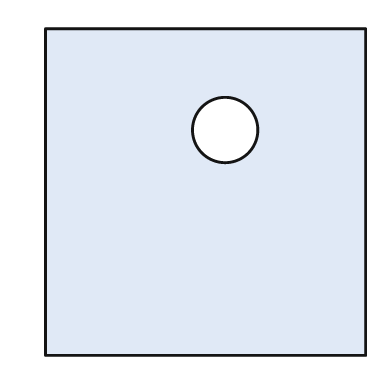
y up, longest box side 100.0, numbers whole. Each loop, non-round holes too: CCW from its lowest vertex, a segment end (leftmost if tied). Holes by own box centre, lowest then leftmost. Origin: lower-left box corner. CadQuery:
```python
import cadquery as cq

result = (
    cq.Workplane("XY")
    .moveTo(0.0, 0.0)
    .lineTo(98.0, 0.0)
    .lineTo(98.0, 100.0)
    .lineTo(0.0, 100.0)
    .close()
    .moveTo(55.0, 69.0)
    .circle(10.0)
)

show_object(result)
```